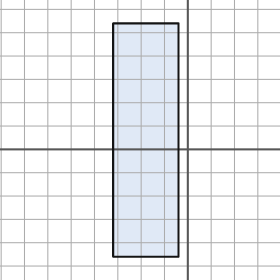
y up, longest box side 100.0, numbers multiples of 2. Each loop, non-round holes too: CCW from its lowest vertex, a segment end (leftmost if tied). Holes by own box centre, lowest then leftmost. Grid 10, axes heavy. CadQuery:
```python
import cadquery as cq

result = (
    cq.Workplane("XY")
    .moveTo(-32.0, -46.0)
    .lineTo(-4.0, -46.0)
    .lineTo(-4.0, 54.0)
    .lineTo(-32.0, 54.0)
    .close()
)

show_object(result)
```